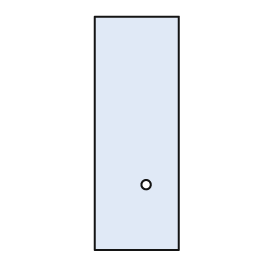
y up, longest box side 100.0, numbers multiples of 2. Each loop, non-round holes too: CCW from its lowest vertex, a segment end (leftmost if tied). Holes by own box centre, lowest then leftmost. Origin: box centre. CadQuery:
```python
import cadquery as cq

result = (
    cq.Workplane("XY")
    .moveTo(-18.0, -50.0)
    .lineTo(18.0, -50.0)
    .lineTo(18.0, 50.0)
    .lineTo(-18.0, 50.0)
    .close()
    .moveTo(4.0, -22.0)
    .circle(2.0)
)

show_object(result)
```